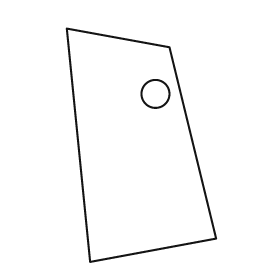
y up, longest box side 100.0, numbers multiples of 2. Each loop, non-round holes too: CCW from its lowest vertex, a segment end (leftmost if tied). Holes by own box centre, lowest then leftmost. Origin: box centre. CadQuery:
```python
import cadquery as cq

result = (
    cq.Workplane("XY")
    .moveTo(-22.0, -50.0)
    .lineTo(32.0, -40.0)
    .lineTo(12.0, 42.0)
    .lineTo(-32.0, 50.0)
    .close()
    .moveTo(6.0, 22.0)
    .circle(6.0)
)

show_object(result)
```